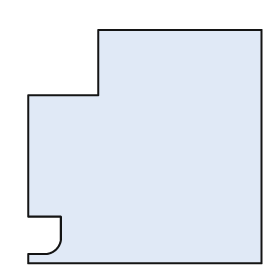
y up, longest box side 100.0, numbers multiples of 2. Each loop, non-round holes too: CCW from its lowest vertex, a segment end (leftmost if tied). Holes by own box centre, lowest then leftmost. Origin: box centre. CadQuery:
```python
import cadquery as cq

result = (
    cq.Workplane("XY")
    .moveTo(-50.0, -50.0)
    .lineTo(50.0, -50.0)
    .lineTo(50.0, 50.0)
    .lineTo(-20.0, 50.0)
    .lineTo(-20.0, 22.0)
    .lineTo(-50.0, 22.0)
    .lineTo(-50.0, -30.0)
    .lineTo(-36.0, -30.0)
    .lineTo(-36.0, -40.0)
    .threePointArc((-38.0, -44.0), (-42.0, -46.0))
    .lineTo(-50.0, -46.0)
    .close()
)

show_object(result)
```